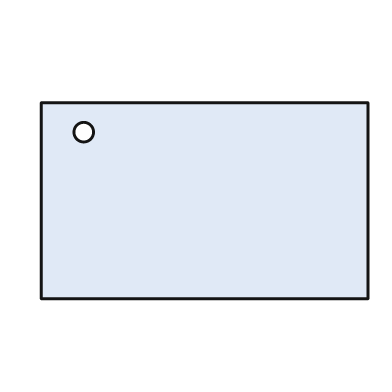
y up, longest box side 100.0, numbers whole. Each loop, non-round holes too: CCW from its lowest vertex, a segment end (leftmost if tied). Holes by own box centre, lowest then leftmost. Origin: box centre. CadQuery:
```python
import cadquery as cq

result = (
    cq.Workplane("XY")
    .moveTo(-50.0, -30.0)
    .lineTo(50.0, -30.0)
    .lineTo(50.0, 30.0)
    .lineTo(-50.0, 30.0)
    .close()
    .moveTo(-37.0, 21.0)
    .circle(3.0)
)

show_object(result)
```